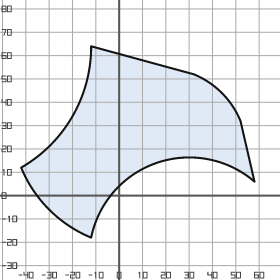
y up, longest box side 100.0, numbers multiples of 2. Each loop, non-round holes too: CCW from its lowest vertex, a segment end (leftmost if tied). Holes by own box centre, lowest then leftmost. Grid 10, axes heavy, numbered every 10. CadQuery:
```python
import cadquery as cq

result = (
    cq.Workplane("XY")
    .moveTo(-12.0, -18.0)
    .threePointArc((16.0, 14.0), (58.0, 6.0))
    .lineTo(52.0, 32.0)
    .threePointArc((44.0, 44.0), (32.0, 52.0))
    .lineTo(-12.0, 64.0)
    .threePointArc((-20.0, 34.0), (-42.0, 12.0))
    .threePointArc((-30.0, -6.0), (-12.0, -18.0))
    .close()
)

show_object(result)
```